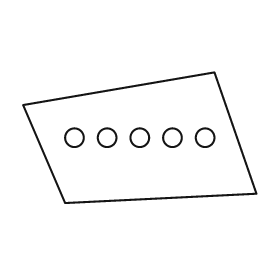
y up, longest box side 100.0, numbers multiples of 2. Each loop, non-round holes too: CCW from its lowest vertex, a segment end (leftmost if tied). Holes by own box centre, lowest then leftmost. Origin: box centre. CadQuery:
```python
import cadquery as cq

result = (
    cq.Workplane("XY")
    .moveTo(-32.0, -28.0)
    .lineTo(50.0, -24.0)
    .lineTo(32.0, 28.0)
    .lineTo(-50.0, 14.0)
    .close()
    .moveTo(-28.0, 0.0)
    .circle(4.0)
    .moveTo(-14.0, 0.0)
    .circle(4.0)
    .moveTo(0.0, 0.0)
    .circle(4.0)
    .moveTo(14.0, 0.0)
    .circle(4.0)
    .moveTo(28.0, 0.0)
    .circle(4.0)
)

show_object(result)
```